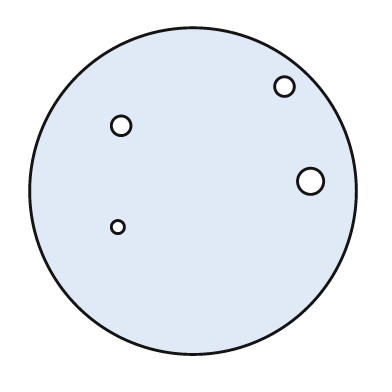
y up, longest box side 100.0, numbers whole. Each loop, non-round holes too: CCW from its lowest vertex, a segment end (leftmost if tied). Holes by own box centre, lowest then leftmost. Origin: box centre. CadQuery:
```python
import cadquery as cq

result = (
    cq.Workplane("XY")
    .moveTo(0.0, 0.0)
    .circle(50.0)
    .moveTo(-23.0, -11.0)
    .circle(2.0)
    .moveTo(36.0, 3.0)
    .circle(4.0)
    .moveTo(-22.0, 20.0)
    .circle(3.0)
    .moveTo(28.0, 32.0)
    .circle(3.0)
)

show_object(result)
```